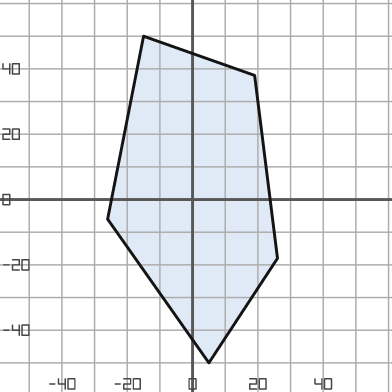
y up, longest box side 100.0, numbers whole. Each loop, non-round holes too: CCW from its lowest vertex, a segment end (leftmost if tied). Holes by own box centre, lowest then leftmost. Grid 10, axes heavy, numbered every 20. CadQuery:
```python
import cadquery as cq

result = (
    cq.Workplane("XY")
    .moveTo(5.0, -50.0)
    .lineTo(26.0, -18.0)
    .lineTo(19.0, 38.0)
    .lineTo(-15.0, 50.0)
    .lineTo(-26.0, -6.0)
    .close()
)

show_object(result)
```